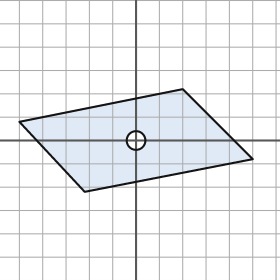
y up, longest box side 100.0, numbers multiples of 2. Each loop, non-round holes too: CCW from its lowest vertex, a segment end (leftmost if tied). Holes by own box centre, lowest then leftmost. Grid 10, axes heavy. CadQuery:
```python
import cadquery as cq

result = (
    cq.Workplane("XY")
    .moveTo(-22.0, -22.0)
    .lineTo(50.0, -8.0)
    .lineTo(20.0, 22.0)
    .lineTo(-50.0, 8.0)
    .close()
    .moveTo(0.0, 0.0)
    .circle(4.0)
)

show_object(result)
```